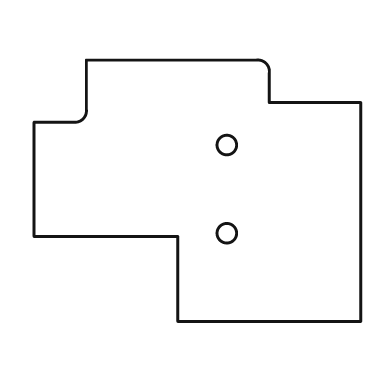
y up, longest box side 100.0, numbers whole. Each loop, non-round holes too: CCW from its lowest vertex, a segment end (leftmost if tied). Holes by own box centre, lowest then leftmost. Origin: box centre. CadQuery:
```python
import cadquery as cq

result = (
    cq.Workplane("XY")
    .moveTo(-6.0, -40.0)
    .lineTo(50.0, -40.0)
    .lineTo(50.0, 27.0)
    .lineTo(22.0, 27.0)
    .lineTo(22.0, 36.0)
    .threePointArc((21.0, 39.0), (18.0, 40.0))
    .lineTo(-34.0, 40.0)
    .lineTo(-34.0, 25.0)
    .threePointArc((-35.0, 22.0), (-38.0, 21.0))
    .lineTo(-50.0, 21.0)
    .lineTo(-50.0, -14.0)
    .lineTo(-6.0, -14.0)
    .close()
    .moveTo(9.0, -13.0)
    .circle(3.0)
    .moveTo(9.0, 14.0)
    .circle(3.0)
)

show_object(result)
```